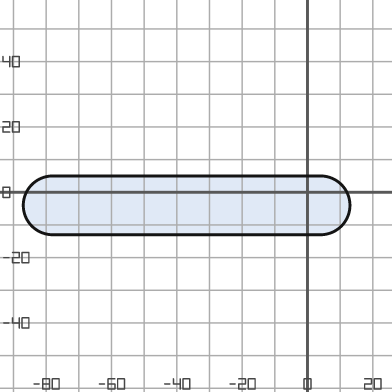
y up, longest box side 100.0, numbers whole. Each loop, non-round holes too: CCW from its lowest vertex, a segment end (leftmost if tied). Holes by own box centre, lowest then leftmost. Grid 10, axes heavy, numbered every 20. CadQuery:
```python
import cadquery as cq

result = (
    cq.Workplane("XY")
    .moveTo(-78.0, -13.0)
    .lineTo(4.0, -13.0)
    .threePointArc((13.0, -4.0), (4.0, 5.0))
    .lineTo(-78.0, 5.0)
    .threePointArc((-87.0, -4.0), (-78.0, -13.0))
    .close()
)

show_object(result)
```